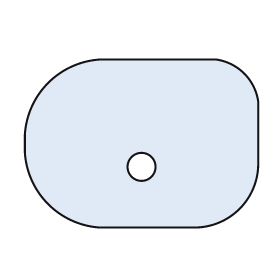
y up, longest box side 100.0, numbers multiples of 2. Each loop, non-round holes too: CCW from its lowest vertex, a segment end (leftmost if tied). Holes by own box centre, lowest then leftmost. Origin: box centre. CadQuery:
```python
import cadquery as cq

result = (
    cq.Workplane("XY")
    .moveTo(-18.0, -36.0)
    .lineTo(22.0, -36.0)
    .threePointArc((42.0, -28.0), (50.0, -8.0))
    .lineTo(50.0, 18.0)
    .threePointArc((44.0, 30.0), (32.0, 36.0))
    .lineTo(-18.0, 36.0)
    .threePointArc((-40.0, 26.0), (-50.0, 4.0))
    .lineTo(-50.0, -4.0)
    .threePointArc((-40.0, -26.0), (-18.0, -36.0))
    .close()
    .moveTo(0.0, -10.0)
    .circle(6.0)
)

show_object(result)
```